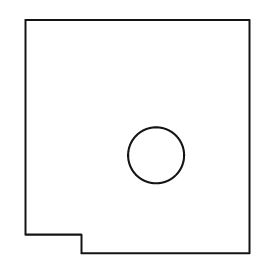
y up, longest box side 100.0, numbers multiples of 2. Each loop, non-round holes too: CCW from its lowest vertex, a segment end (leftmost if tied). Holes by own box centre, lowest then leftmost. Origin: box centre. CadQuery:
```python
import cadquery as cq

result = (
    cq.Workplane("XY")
    .moveTo(-24.0, -50.0)
    .lineTo(48.0, -50.0)
    .lineTo(48.0, 50.0)
    .lineTo(-48.0, 50.0)
    .lineTo(-48.0, -42.0)
    .lineTo(-24.0, -42.0)
    .close()
    .moveTo(8.0, -8.0)
    .circle(12.0)
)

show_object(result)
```